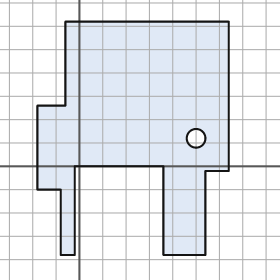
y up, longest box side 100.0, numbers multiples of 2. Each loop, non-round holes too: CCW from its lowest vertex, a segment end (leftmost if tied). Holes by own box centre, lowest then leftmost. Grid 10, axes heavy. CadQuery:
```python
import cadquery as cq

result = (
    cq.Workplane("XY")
    .moveTo(-8.0, -38.0)
    .lineTo(-2.0, -38.0)
    .lineTo(-2.0, 0.0)
    .lineTo(36.0, 0.0)
    .lineTo(36.0, -38.0)
    .lineTo(54.0, -38.0)
    .lineTo(54.0, -2.0)
    .lineTo(64.0, -2.0)
    .lineTo(64.0, 62.0)
    .lineTo(-6.0, 62.0)
    .lineTo(-6.0, 26.0)
    .lineTo(-18.0, 26.0)
    .lineTo(-18.0, -10.0)
    .lineTo(-8.0, -10.0)
    .close()
    .moveTo(50.0, 12.0)
    .circle(4.0)
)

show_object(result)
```